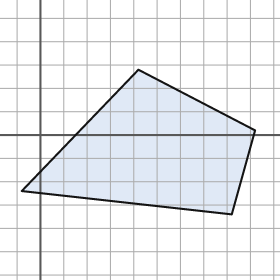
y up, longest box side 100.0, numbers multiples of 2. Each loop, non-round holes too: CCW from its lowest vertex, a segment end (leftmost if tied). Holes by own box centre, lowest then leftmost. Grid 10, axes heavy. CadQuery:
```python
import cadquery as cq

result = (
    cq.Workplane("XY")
    .moveTo(82.0, -34.0)
    .lineTo(92.0, 2.0)
    .lineTo(42.0, 28.0)
    .lineTo(-8.0, -24.0)
    .close()
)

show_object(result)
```